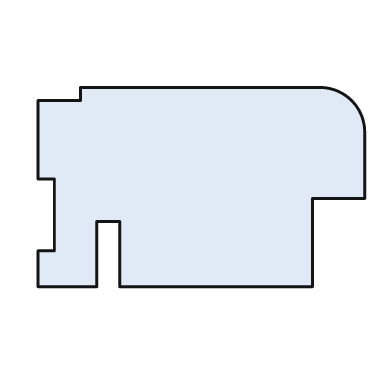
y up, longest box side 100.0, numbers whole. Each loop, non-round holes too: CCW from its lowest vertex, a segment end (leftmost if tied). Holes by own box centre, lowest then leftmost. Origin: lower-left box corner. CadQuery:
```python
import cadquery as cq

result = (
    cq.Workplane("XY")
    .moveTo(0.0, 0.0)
    .lineTo(18.0, 0.0)
    .lineTo(18.0, 20.0)
    .lineTo(25.0, 20.0)
    .lineTo(25.0, 0.0)
    .lineTo(84.0, 0.0)
    .lineTo(84.0, 27.0)
    .lineTo(100.0, 27.0)
    .lineTo(100.0, 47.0)
    .threePointArc((96.0, 57.0), (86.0, 61.0))
    .lineTo(13.0, 61.0)
    .lineTo(13.0, 57.0)
    .lineTo(0.0, 57.0)
    .lineTo(0.0, 33.0)
    .lineTo(5.0, 33.0)
    .lineTo(5.0, 11.0)
    .lineTo(0.0, 11.0)
    .close()
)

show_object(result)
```